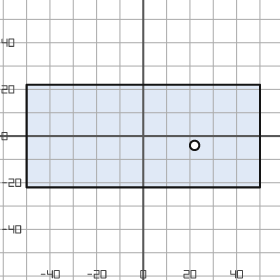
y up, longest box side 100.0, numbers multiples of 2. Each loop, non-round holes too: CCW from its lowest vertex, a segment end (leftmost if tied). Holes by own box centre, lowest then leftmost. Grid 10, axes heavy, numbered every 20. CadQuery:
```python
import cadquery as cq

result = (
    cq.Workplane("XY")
    .moveTo(-50.0, -22.0)
    .lineTo(50.0, -22.0)
    .lineTo(50.0, 22.0)
    .lineTo(-50.0, 22.0)
    .close()
    .moveTo(22.0, -4.0)
    .circle(2.0)
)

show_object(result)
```